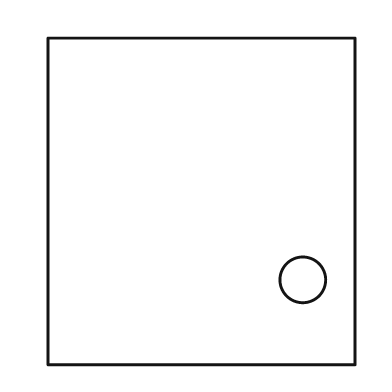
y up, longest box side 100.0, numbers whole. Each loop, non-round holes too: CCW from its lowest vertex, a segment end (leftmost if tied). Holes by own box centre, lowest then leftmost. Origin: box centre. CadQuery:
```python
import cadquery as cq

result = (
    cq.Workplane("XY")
    .moveTo(-47.0, -50.0)
    .lineTo(47.0, -50.0)
    .lineTo(47.0, 50.0)
    .lineTo(-47.0, 50.0)
    .close()
    .moveTo(31.0, -24.0)
    .circle(7.0)
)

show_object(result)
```